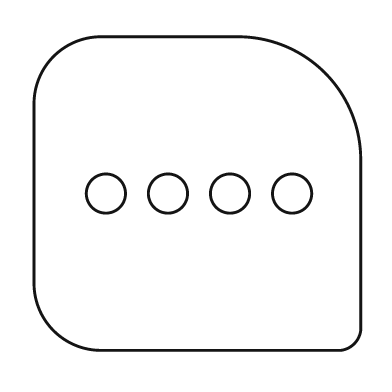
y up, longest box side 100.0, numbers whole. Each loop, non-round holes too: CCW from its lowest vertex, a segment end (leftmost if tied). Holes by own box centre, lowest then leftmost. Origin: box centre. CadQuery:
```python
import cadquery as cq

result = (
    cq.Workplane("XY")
    .moveTo(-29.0, -48.0)
    .lineTo(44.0, -48.0)
    .threePointArc((48.0, -46.0), (50.0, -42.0))
    .lineTo(50.0, 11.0)
    .threePointArc((39.0, 37.0), (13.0, 48.0))
    .lineTo(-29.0, 48.0)
    .threePointArc((-44.0, 42.0), (-50.0, 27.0))
    .lineTo(-50.0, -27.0)
    .threePointArc((-44.0, -42.0), (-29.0, -48.0))
    .close()
    .moveTo(-28.0, 0.0)
    .circle(6.0)
    .moveTo(-9.0, 0.0)
    .circle(6.0)
    .moveTo(10.0, 0.0)
    .circle(6.0)
    .moveTo(29.0, 0.0)
    .circle(6.0)
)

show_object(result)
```